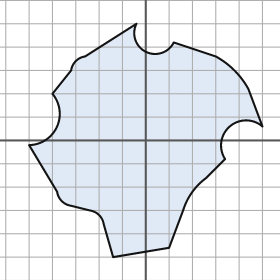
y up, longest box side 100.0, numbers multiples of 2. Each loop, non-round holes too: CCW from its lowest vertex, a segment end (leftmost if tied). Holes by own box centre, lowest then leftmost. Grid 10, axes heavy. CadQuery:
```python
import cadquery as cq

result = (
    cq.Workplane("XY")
    .moveTo(-14.0, -50.0)
    .lineTo(10.0, -46.0)
    .lineTo(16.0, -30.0)
    .threePointArc((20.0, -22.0), (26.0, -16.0))
    .lineTo(34.0, -8.0)
    .threePointArc((36.0, 6.0), (50.0, 6.0))
    .lineTo(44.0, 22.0)
    .threePointArc((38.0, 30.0), (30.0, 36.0))
    .lineTo(12.0, 42.0)
    .threePointArc((0.0, 38.0), (-4.0, 50.0))
    .lineTo(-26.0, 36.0)
    .threePointArc((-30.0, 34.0), (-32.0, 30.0))
    .lineTo(-40.0, 20.0)
    .threePointArc((-38.0, 6.0), (-50.0, -2.0))
    .lineTo(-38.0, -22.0)
    .threePointArc((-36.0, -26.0), (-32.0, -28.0))
    .lineTo(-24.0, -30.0)
    .threePointArc((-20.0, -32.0), (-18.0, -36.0))
    .close()
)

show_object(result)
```